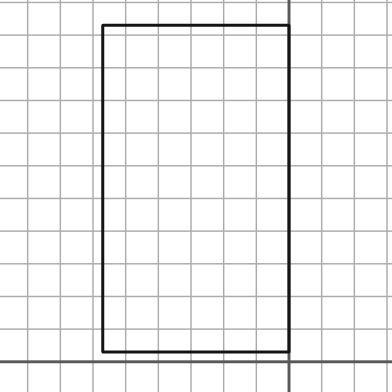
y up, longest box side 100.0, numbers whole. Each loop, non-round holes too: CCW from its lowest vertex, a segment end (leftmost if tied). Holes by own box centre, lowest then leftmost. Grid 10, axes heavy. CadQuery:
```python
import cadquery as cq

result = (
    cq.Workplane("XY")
    .moveTo(-57.0, 3.0)
    .lineTo(0.0, 3.0)
    .lineTo(0.0, 103.0)
    .lineTo(-57.0, 103.0)
    .close()
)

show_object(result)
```